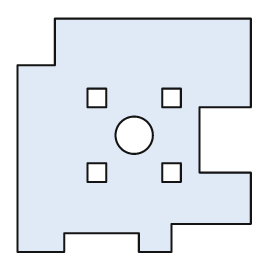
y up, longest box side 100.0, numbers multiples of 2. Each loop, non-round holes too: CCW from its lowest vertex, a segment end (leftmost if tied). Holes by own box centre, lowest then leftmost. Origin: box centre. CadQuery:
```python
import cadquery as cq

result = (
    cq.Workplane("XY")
    .moveTo(-50.0, -50.0)
    .lineTo(-30.0, -50.0)
    .lineTo(-30.0, -42.0)
    .lineTo(2.0, -42.0)
    .lineTo(2.0, -50.0)
    .lineTo(16.0, -50.0)
    .lineTo(16.0, -38.0)
    .lineTo(50.0, -38.0)
    .lineTo(50.0, -16.0)
    .lineTo(28.0, -16.0)
    .lineTo(28.0, 12.0)
    .lineTo(50.0, 12.0)
    .lineTo(50.0, 50.0)
    .lineTo(-34.0, 50.0)
    .lineTo(-34.0, 30.0)
    .lineTo(-50.0, 30.0)
    .close()
    .moveTo(-20.0, -20.0)
    .lineTo(-12.0, -20.0)
    .lineTo(-12.0, -12.0)
    .lineTo(-20.0, -12.0)
    .close()
    .moveTo(12.0, -20.0)
    .lineTo(20.0, -20.0)
    .lineTo(20.0, -12.0)
    .lineTo(12.0, -12.0)
    .close()
    .moveTo(0.0, 0.0)
    .circle(8.0)
    .moveTo(-20.0, 12.0)
    .lineTo(-12.0, 12.0)
    .lineTo(-12.0, 20.0)
    .lineTo(-20.0, 20.0)
    .close()
    .moveTo(12.0, 12.0)
    .lineTo(20.0, 12.0)
    .lineTo(20.0, 20.0)
    .lineTo(12.0, 20.0)
    .close()
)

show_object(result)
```